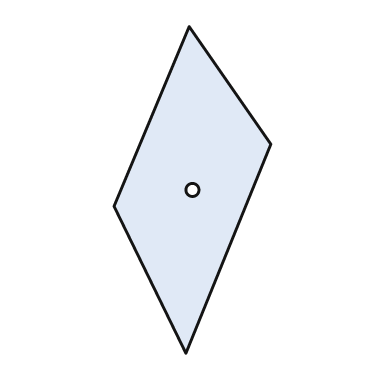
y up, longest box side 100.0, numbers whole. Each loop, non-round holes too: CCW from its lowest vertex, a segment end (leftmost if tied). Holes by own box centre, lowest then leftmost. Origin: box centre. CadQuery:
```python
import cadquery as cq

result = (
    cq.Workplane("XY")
    .moveTo(-2.0, -50.0)
    .lineTo(24.0, 14.0)
    .lineTo(-1.0, 50.0)
    .lineTo(-24.0, -5.0)
    .close()
    .moveTo(0.0, 0.0)
    .circle(2.0)
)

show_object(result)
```